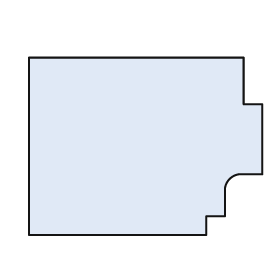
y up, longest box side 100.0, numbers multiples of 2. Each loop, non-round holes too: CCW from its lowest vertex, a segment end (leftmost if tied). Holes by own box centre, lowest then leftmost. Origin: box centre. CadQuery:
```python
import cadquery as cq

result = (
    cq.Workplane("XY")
    .moveTo(-50.0, -38.0)
    .lineTo(26.0, -38.0)
    .lineTo(26.0, -30.0)
    .lineTo(34.0, -30.0)
    .lineTo(34.0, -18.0)
    .threePointArc((36.0, -14.0), (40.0, -12.0))
    .lineTo(50.0, -12.0)
    .lineTo(50.0, 18.0)
    .lineTo(42.0, 18.0)
    .lineTo(42.0, 38.0)
    .lineTo(-50.0, 38.0)
    .close()
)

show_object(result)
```